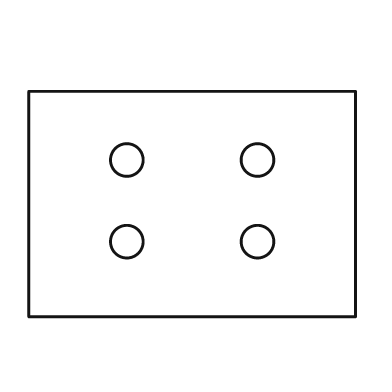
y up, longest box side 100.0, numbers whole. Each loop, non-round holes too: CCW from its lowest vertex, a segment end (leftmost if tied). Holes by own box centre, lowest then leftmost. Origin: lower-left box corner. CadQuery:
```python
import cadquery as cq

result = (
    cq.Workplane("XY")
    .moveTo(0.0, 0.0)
    .lineTo(100.0, 0.0)
    .lineTo(100.0, 69.0)
    .lineTo(0.0, 69.0)
    .close()
    .moveTo(30.0, 23.0)
    .circle(5.0)
    .moveTo(70.0, 23.0)
    .circle(5.0)
    .moveTo(30.0, 48.0)
    .circle(5.0)
    .moveTo(70.0, 48.0)
    .circle(5.0)
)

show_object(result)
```